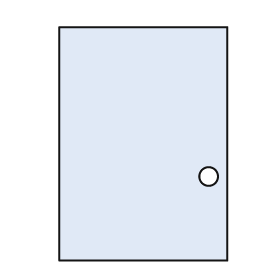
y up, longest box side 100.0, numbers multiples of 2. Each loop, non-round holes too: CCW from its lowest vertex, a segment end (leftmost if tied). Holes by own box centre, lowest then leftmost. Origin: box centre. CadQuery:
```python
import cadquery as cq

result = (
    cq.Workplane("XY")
    .moveTo(-36.0, -50.0)
    .lineTo(36.0, -50.0)
    .lineTo(36.0, 50.0)
    .lineTo(-36.0, 50.0)
    .close()
    .moveTo(28.0, -14.0)
    .circle(4.0)
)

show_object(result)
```